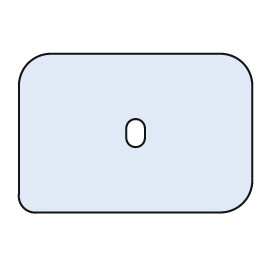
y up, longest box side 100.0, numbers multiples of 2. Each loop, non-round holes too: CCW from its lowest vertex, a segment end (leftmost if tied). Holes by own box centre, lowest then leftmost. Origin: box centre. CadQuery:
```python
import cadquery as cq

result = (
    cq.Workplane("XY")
    .moveTo(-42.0, -34.0)
    .lineTo(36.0, -34.0)
    .threePointArc((46.0, -30.0), (50.0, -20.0))
    .lineTo(50.0, 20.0)
    .threePointArc((46.0, 30.0), (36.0, 34.0))
    .lineTo(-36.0, 34.0)
    .threePointArc((-46.0, 30.0), (-50.0, 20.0))
    .lineTo(-50.0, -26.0)
    .threePointArc((-48.0, -32.0), (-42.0, -34.0))
    .close()
    .moveTo(-4.0, -2.0)
    .threePointArc((0.0, -6.0), (4.0, -2.0))
    .lineTo(4.0, 2.0)
    .threePointArc((0.0, 6.0), (-4.0, 2.0))
    .close()
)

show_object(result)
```